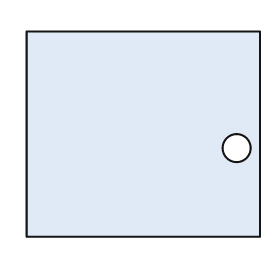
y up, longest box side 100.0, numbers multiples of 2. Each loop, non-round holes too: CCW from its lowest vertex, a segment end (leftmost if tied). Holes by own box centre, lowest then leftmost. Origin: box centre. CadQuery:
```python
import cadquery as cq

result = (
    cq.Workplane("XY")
    .moveTo(-50.0, -44.0)
    .lineTo(50.0, -44.0)
    .lineTo(50.0, 44.0)
    .lineTo(-50.0, 44.0)
    .close()
    .moveTo(40.0, -6.0)
    .circle(6.0)
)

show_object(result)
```